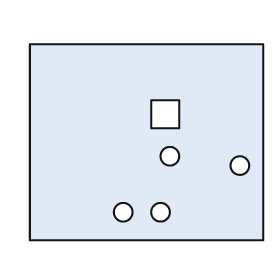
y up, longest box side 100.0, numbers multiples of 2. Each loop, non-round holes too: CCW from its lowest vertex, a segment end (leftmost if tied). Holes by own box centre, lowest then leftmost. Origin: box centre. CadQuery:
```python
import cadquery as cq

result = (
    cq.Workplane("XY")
    .moveTo(-50.0, -42.0)
    .lineTo(50.0, -42.0)
    .lineTo(50.0, 42.0)
    .lineTo(-50.0, 42.0)
    .close()
    .moveTo(-10.0, -30.0)
    .circle(4.0)
    .moveTo(6.0, -30.0)
    .circle(4.0)
    .moveTo(40.0, -10.0)
    .circle(4.0)
    .moveTo(10.0, -6.0)
    .circle(4.0)
    .moveTo(2.0, 6.0)
    .lineTo(14.0, 6.0)
    .lineTo(14.0, 18.0)
    .lineTo(2.0, 18.0)
    .close()
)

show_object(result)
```